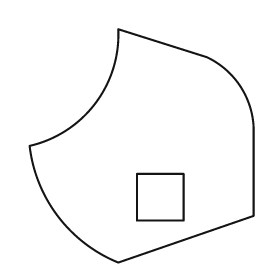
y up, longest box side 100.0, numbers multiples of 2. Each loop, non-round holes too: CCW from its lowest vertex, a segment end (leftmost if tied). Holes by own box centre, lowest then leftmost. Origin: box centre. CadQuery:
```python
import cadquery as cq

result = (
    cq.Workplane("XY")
    .moveTo(-10.0, -50.0)
    .lineTo(48.0, -30.0)
    .lineTo(48.0, 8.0)
    .threePointArc((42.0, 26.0), (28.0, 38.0))
    .lineTo(-10.0, 50.0)
    .threePointArc((-20.0, 18.0), (-48.0, 0.0))
    .threePointArc((-36.0, -30.0), (-10.0, -50.0))
    .close()
    .moveTo(-2.0, -32.0)
    .lineTo(18.0, -32.0)
    .lineTo(18.0, -12.0)
    .lineTo(-2.0, -12.0)
    .close()
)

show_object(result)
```